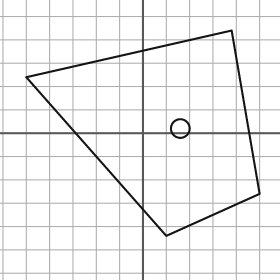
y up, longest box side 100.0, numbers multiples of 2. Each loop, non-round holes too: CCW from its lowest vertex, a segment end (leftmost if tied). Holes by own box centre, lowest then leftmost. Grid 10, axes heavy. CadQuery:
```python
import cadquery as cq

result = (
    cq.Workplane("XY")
    .moveTo(10.0, -44.0)
    .lineTo(50.0, -26.0)
    .lineTo(38.0, 44.0)
    .lineTo(-50.0, 24.0)
    .close()
    .moveTo(16.0, 2.0)
    .circle(4.0)
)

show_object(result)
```